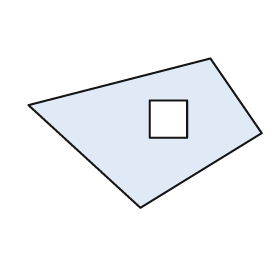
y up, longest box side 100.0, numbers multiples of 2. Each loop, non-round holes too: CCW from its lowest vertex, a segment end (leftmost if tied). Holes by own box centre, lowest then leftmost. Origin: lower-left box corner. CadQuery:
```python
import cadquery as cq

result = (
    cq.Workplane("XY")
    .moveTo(48.0, 0.0)
    .lineTo(100.0, 32.0)
    .lineTo(78.0, 64.0)
    .lineTo(0.0, 44.0)
    .close()
    .moveTo(52.0, 30.0)
    .lineTo(68.0, 30.0)
    .lineTo(68.0, 46.0)
    .lineTo(52.0, 46.0)
    .close()
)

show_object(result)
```